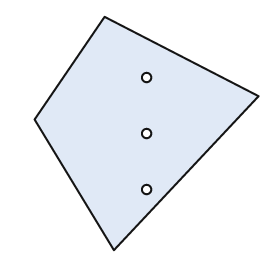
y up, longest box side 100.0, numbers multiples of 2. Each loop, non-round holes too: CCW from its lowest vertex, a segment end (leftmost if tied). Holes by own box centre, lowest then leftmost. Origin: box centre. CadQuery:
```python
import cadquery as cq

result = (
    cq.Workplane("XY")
    .moveTo(-14.0, -50.0)
    .lineTo(48.0, 16.0)
    .lineTo(-18.0, 50.0)
    .lineTo(-48.0, 6.0)
    .close()
    .moveTo(0.0, -24.0)
    .circle(2.0)
    .moveTo(0.0, 0.0)
    .circle(2.0)
    .moveTo(0.0, 24.0)
    .circle(2.0)
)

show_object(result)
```